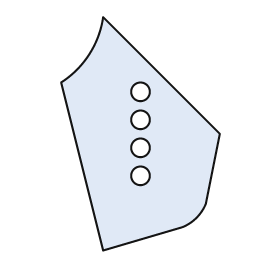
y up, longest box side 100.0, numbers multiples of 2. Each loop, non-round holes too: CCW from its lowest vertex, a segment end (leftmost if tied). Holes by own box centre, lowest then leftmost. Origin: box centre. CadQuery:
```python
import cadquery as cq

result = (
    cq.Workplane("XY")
    .moveTo(-16.0, -50.0)
    .lineTo(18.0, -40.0)
    .threePointArc((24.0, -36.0), (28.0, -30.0))
    .lineTo(34.0, 0.0)
    .lineTo(-16.0, 50.0)
    .threePointArc((-22.0, 34.0), (-34.0, 22.0))
    .close()
    .moveTo(0.0, -18.0)
    .circle(4.0)
    .moveTo(0.0, -6.0)
    .circle(4.0)
    .moveTo(0.0, 6.0)
    .circle(4.0)
    .moveTo(0.0, 18.0)
    .circle(4.0)
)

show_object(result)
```